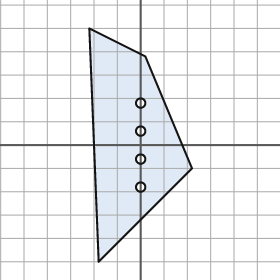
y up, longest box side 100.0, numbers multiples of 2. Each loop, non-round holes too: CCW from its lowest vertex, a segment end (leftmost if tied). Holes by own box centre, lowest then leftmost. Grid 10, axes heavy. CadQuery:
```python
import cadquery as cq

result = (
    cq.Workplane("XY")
    .moveTo(-18.0, -50.0)
    .lineTo(22.0, -10.0)
    .lineTo(2.0, 38.0)
    .lineTo(-22.0, 50.0)
    .close()
    .moveTo(0.0, -18.0)
    .circle(2.0)
    .moveTo(0.0, -6.0)
    .circle(2.0)
    .moveTo(0.0, 6.0)
    .circle(2.0)
    .moveTo(0.0, 18.0)
    .circle(2.0)
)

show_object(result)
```